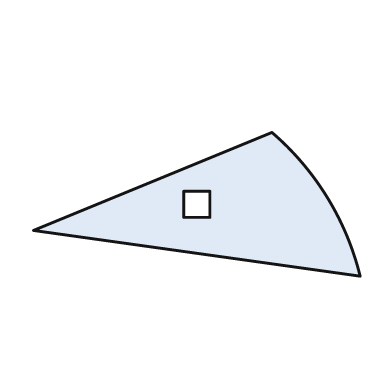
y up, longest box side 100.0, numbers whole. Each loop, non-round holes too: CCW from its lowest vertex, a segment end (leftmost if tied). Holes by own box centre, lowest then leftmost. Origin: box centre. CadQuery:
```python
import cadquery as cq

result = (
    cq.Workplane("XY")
    .moveTo(50.0, -22.0)
    .threePointArc((40.0, 2.0), (23.0, 22.0))
    .lineTo(-50.0, -8.0)
    .close()
    .moveTo(-4.0, -4.0)
    .lineTo(4.0, -4.0)
    .lineTo(4.0, 4.0)
    .lineTo(-4.0, 4.0)
    .close()
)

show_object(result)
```